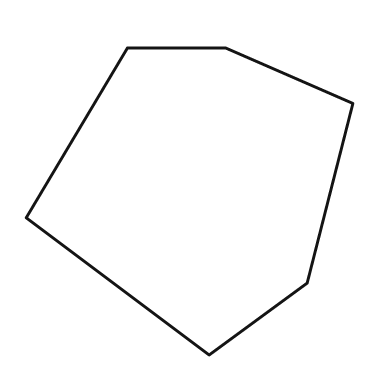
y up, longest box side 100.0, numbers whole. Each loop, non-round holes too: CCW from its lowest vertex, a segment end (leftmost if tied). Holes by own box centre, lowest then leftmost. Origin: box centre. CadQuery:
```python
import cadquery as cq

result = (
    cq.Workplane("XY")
    .moveTo(6.0, -47.0)
    .lineTo(36.0, -25.0)
    .lineTo(50.0, 30.0)
    .lineTo(11.0, 47.0)
    .lineTo(-19.0, 47.0)
    .lineTo(-50.0, -5.0)
    .close()
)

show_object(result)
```